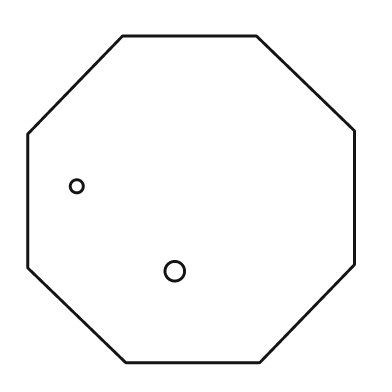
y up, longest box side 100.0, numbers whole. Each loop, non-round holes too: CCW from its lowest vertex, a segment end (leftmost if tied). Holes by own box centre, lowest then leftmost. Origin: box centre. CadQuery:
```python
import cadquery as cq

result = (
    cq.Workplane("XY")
    .moveTo(-20.0, -50.0)
    .lineTo(21.0, -50.0)
    .lineTo(50.0, -20.0)
    .lineTo(50.0, 21.0)
    .lineTo(20.0, 50.0)
    .lineTo(-21.0, 50.0)
    .lineTo(-50.0, 20.0)
    .lineTo(-50.0, -21.0)
    .close()
    .moveTo(-5.0, -22.0)
    .circle(3.0)
    .moveTo(-35.0, 4.0)
    .circle(2.0)
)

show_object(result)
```